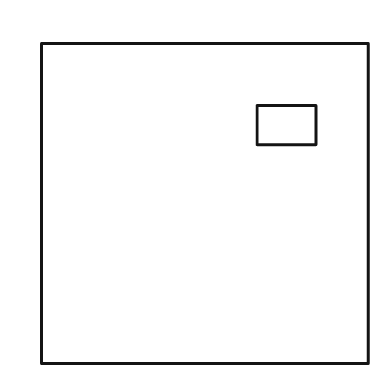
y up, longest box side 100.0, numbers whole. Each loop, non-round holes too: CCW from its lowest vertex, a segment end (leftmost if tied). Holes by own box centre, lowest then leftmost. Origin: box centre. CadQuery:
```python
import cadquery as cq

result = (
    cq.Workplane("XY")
    .moveTo(-50.0, -49.0)
    .lineTo(50.0, -49.0)
    .lineTo(50.0, 49.0)
    .lineTo(-50.0, 49.0)
    .close()
    .moveTo(16.0, 18.0)
    .lineTo(34.0, 18.0)
    .lineTo(34.0, 30.0)
    .lineTo(16.0, 30.0)
    .close()
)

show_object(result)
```